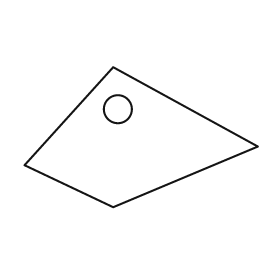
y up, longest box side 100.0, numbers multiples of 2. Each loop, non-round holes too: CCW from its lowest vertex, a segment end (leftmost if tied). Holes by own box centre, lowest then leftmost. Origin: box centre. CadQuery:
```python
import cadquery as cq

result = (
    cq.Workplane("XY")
    .moveTo(-12.0, -30.0)
    .lineTo(50.0, -4.0)
    .lineTo(-12.0, 30.0)
    .lineTo(-50.0, -12.0)
    .close()
    .moveTo(-10.0, 12.0)
    .circle(6.0)
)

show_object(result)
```